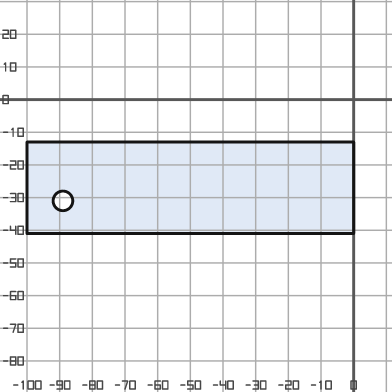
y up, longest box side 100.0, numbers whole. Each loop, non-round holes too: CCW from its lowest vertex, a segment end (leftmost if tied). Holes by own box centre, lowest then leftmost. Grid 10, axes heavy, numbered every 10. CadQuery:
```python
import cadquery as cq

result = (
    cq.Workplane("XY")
    .moveTo(-100.0, -41.0)
    .lineTo(0.0, -41.0)
    .lineTo(0.0, -13.0)
    .lineTo(-100.0, -13.0)
    .close()
    .moveTo(-89.0, -31.0)
    .circle(3.0)
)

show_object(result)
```